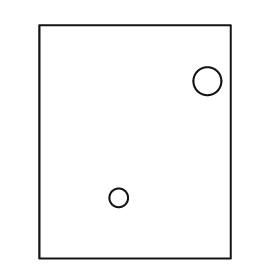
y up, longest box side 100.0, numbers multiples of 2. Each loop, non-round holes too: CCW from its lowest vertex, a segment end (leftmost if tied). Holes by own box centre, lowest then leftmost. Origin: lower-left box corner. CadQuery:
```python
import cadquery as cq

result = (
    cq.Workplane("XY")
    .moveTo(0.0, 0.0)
    .lineTo(82.0, 0.0)
    .lineTo(82.0, 100.0)
    .lineTo(0.0, 100.0)
    .close()
    .moveTo(34.0, 26.0)
    .circle(4.0)
    .moveTo(72.0, 76.0)
    .circle(6.0)
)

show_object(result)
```